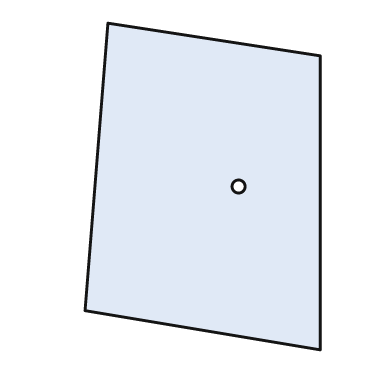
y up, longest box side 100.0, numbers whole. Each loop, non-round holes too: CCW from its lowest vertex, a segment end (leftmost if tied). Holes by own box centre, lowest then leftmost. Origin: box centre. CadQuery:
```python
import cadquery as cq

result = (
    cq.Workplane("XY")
    .moveTo(36.0, -50.0)
    .lineTo(36.0, 40.0)
    .lineTo(-29.0, 50.0)
    .lineTo(-36.0, -38.0)
    .close()
    .moveTo(11.0, 0.0)
    .circle(2.0)
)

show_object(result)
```